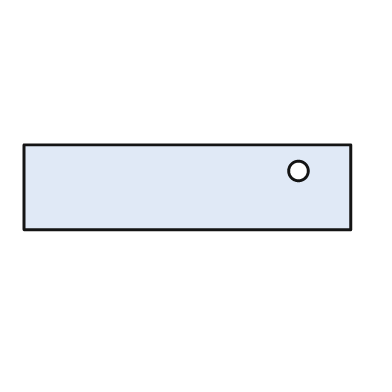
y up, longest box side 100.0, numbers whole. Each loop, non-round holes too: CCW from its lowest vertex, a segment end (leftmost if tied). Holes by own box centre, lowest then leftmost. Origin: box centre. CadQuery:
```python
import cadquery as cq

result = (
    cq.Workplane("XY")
    .moveTo(-50.0, -13.0)
    .lineTo(50.0, -13.0)
    .lineTo(50.0, 13.0)
    .lineTo(-50.0, 13.0)
    .close()
    .moveTo(34.0, 5.0)
    .circle(3.0)
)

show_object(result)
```